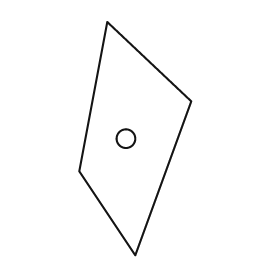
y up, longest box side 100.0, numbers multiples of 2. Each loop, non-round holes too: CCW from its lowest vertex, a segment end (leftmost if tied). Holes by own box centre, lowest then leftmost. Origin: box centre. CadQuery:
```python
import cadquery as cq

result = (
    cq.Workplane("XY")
    .moveTo(0.0, -50.0)
    .lineTo(24.0, 16.0)
    .lineTo(-12.0, 50.0)
    .lineTo(-24.0, -14.0)
    .close()
    .moveTo(-4.0, 0.0)
    .circle(4.0)
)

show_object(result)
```